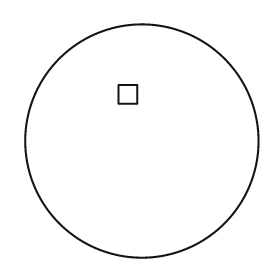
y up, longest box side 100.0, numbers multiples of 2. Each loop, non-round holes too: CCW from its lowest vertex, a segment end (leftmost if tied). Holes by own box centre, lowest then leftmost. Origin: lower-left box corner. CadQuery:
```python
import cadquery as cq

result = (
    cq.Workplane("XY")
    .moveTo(50.0, 50.0)
    .circle(50.0)
    .moveTo(40.0, 66.0)
    .lineTo(48.0, 66.0)
    .lineTo(48.0, 74.0)
    .lineTo(40.0, 74.0)
    .close()
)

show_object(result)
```